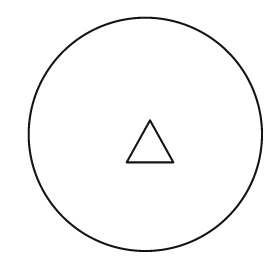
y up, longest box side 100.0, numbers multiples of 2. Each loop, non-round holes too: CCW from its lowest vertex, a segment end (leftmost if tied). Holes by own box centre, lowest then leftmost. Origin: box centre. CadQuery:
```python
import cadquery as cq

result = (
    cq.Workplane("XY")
    .moveTo(0.0, 0.0)
    .circle(50.0)
    .moveTo(-8.0, -12.0)
    .lineTo(12.0, -12.0)
    .lineTo(2.0, 6.0)
    .close()
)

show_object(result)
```